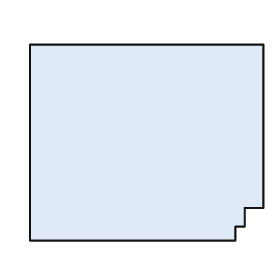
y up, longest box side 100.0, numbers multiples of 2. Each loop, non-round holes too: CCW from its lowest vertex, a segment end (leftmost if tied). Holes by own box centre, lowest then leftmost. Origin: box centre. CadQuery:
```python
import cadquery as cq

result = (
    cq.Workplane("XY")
    .moveTo(-50.0, -42.0)
    .lineTo(38.0, -42.0)
    .lineTo(38.0, -36.0)
    .lineTo(42.0, -36.0)
    .lineTo(42.0, -28.0)
    .lineTo(50.0, -28.0)
    .lineTo(50.0, 42.0)
    .lineTo(-50.0, 42.0)
    .close()
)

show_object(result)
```